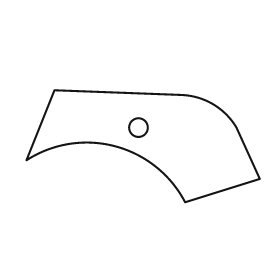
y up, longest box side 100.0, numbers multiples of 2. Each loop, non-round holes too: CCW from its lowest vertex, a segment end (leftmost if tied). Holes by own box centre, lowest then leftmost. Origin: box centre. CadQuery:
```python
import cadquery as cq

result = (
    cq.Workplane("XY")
    .moveTo(18.0, -24.0)
    .lineTo(50.0, -14.0)
    .lineTo(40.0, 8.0)
    .threePointArc((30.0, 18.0), (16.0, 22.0))
    .lineTo(-38.0, 24.0)
    .lineTo(-50.0, -6.0)
    .threePointArc((-12.0, 0.0), (18.0, -24.0))
    .close()
    .moveTo(-2.0, 8.0)
    .circle(4.0)
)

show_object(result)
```